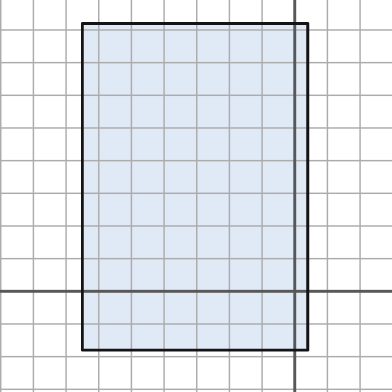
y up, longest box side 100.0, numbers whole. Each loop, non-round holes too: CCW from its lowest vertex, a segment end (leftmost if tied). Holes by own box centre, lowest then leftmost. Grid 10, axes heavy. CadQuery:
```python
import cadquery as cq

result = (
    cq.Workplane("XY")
    .moveTo(-65.0, -18.0)
    .lineTo(4.0, -18.0)
    .lineTo(4.0, 82.0)
    .lineTo(-65.0, 82.0)
    .close()
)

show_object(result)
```